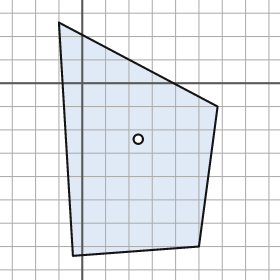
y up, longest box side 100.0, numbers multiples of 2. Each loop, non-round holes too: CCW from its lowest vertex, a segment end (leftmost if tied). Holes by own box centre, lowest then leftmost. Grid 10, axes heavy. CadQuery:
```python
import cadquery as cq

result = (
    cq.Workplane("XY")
    .moveTo(-4.0, -74.0)
    .lineTo(50.0, -70.0)
    .lineTo(58.0, -10.0)
    .lineTo(-10.0, 26.0)
    .close()
    .moveTo(24.0, -24.0)
    .circle(2.0)
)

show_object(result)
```